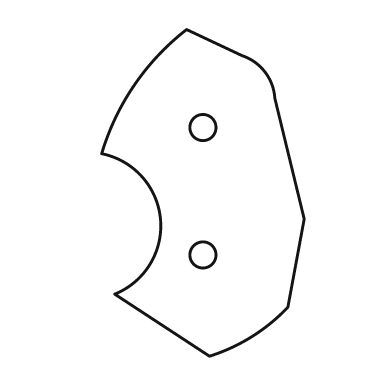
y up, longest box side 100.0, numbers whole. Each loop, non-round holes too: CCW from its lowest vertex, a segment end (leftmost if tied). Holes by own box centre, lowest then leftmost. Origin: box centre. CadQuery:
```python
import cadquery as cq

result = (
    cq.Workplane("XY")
    .moveTo(2.0, -50.0)
    .threePointArc((15.0, -44.0), (26.0, -35.0))
    .lineTo(31.0, -8.0)
    .lineTo(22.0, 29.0)
    .threePointArc((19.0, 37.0), (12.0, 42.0))
    .lineTo(-5.0, 50.0)
    .threePointArc((-21.0, 33.0), (-31.0, 12.0))
    .threePointArc((-13.0, -8.0), (-27.0, -31.0))
    .close()
    .moveTo(0.0, -19.0)
    .circle(4.0)
    .moveTo(0.0, 20.0)
    .circle(4.0)
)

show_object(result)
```